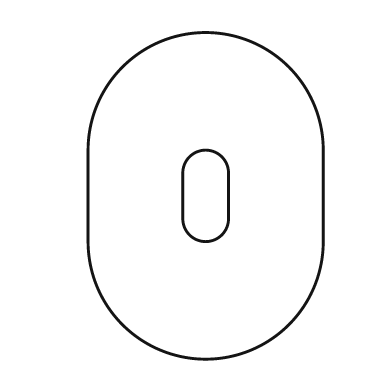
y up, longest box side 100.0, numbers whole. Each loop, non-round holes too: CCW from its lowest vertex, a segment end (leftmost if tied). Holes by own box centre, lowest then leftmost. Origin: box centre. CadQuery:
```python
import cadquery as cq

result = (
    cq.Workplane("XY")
    .moveTo(-36.0, -14.0)
    .threePointArc((0.0, -50.0), (36.0, -14.0))
    .lineTo(36.0, 14.0)
    .threePointArc((0.0, 50.0), (-36.0, 14.0))
    .close()
    .moveTo(-7.0, -7.0)
    .threePointArc((0.0, -14.0), (7.0, -7.0))
    .lineTo(7.0, 7.0)
    .threePointArc((0.0, 14.0), (-7.0, 7.0))
    .close()
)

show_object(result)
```